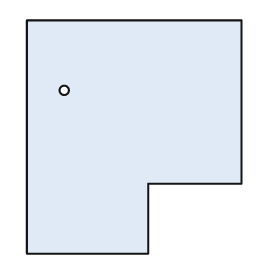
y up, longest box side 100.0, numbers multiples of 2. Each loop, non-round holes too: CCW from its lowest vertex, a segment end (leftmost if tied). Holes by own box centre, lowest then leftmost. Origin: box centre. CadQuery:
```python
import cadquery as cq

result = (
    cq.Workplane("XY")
    .moveTo(-46.0, -50.0)
    .lineTo(6.0, -50.0)
    .lineTo(6.0, -20.0)
    .lineTo(46.0, -20.0)
    .lineTo(46.0, 50.0)
    .lineTo(-46.0, 50.0)
    .close()
    .moveTo(-30.0, 20.0)
    .circle(2.0)
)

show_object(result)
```